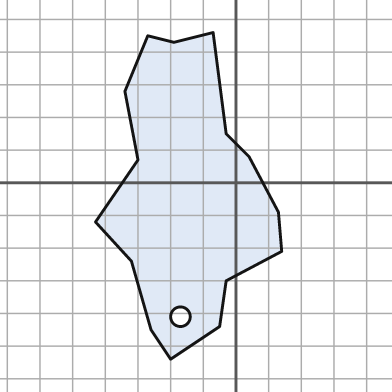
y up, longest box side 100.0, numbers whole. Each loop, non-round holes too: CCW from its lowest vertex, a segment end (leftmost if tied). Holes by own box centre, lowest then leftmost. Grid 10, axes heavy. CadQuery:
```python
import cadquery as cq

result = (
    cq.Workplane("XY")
    .moveTo(-20.0, -54.0)
    .lineTo(-5.0, -44.0)
    .lineTo(-3.0, -30.0)
    .lineTo(14.0, -21.0)
    .lineTo(13.0, -9.0)
    .lineTo(4.0, 8.0)
    .lineTo(-3.0, 15.0)
    .lineTo(-7.0, 46.0)
    .lineTo(-19.0, 43.0)
    .lineTo(-27.0, 45.0)
    .lineTo(-34.0, 28.0)
    .lineTo(-30.0, 7.0)
    .lineTo(-43.0, -12.0)
    .lineTo(-32.0, -24.0)
    .lineTo(-26.0, -45.0)
    .close()
    .moveTo(-17.0, -41.0)
    .circle(3.0)
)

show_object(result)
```